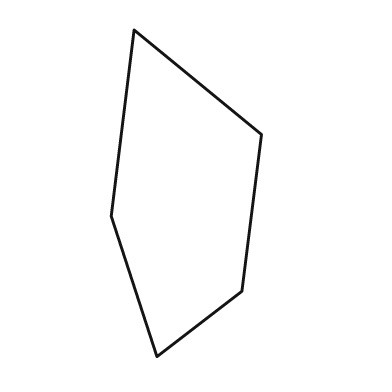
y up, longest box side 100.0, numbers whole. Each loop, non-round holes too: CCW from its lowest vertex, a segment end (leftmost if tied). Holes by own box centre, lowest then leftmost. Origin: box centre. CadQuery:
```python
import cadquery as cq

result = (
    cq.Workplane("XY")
    .moveTo(-9.0, -50.0)
    .lineTo(17.0, -30.0)
    .lineTo(23.0, 18.0)
    .lineTo(-16.0, 50.0)
    .lineTo(-23.0, -7.0)
    .close()
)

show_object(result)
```